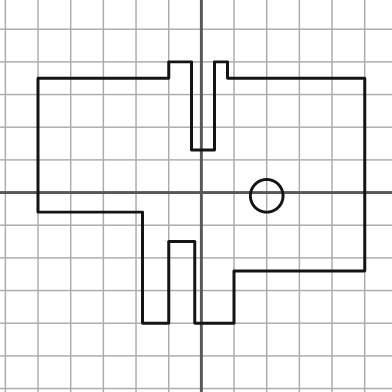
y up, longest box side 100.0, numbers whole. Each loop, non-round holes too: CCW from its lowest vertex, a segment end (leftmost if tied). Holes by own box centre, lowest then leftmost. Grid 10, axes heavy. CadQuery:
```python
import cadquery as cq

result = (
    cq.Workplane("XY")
    .moveTo(-18.0, -40.0)
    .lineTo(-10.0, -40.0)
    .lineTo(-10.0, -15.0)
    .lineTo(-2.0, -15.0)
    .lineTo(-2.0, -40.0)
    .lineTo(10.0, -40.0)
    .lineTo(10.0, -24.0)
    .lineTo(50.0, -24.0)
    .lineTo(50.0, 35.0)
    .lineTo(8.0, 35.0)
    .lineTo(8.0, 40.0)
    .lineTo(4.0, 40.0)
    .lineTo(4.0, 13.0)
    .lineTo(-3.0, 13.0)
    .lineTo(-3.0, 40.0)
    .lineTo(-10.0, 40.0)
    .lineTo(-10.0, 35.0)
    .lineTo(-50.0, 35.0)
    .lineTo(-50.0, -6.0)
    .lineTo(-18.0, -6.0)
    .close()
    .moveTo(20.0, -1.0)
    .circle(5.0)
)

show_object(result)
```